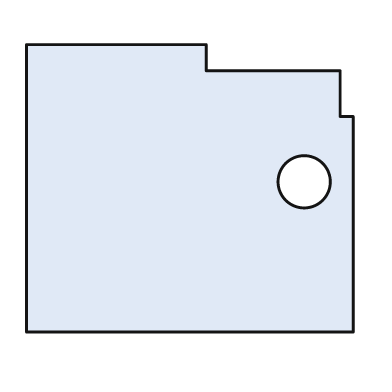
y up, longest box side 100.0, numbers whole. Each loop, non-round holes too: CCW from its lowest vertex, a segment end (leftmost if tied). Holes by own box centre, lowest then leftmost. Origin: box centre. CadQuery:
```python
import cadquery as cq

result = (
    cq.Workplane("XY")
    .moveTo(-50.0, -44.0)
    .lineTo(50.0, -44.0)
    .lineTo(50.0, 22.0)
    .lineTo(46.0, 22.0)
    .lineTo(46.0, 36.0)
    .lineTo(5.0, 36.0)
    .lineTo(5.0, 44.0)
    .lineTo(-50.0, 44.0)
    .close()
    .moveTo(35.0, 2.0)
    .circle(8.0)
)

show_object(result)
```